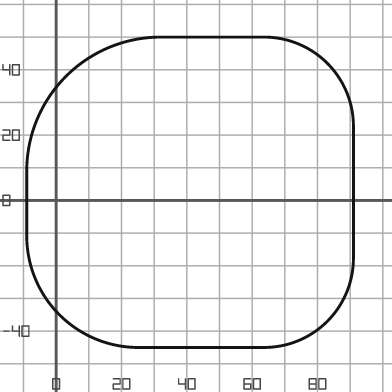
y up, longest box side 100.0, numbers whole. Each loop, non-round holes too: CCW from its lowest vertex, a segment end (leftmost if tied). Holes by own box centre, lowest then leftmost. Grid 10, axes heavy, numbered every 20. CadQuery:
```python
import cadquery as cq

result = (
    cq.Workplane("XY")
    .moveTo(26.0, -45.0)
    .lineTo(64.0, -45.0)
    .threePointArc((83.0, -37.0), (91.0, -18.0))
    .lineTo(91.0, 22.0)
    .threePointArc((83.0, 42.0), (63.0, 50.0))
    .lineTo(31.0, 50.0)
    .threePointArc((3.0, 38.0), (-9.0, 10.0))
    .lineTo(-9.0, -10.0)
    .threePointArc((1.0, -35.0), (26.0, -45.0))
    .close()
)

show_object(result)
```